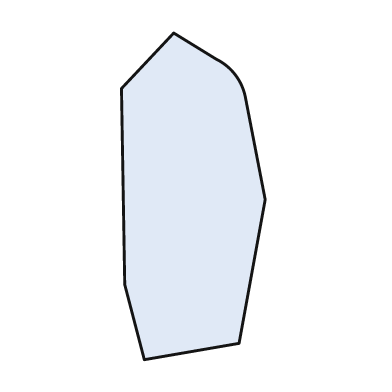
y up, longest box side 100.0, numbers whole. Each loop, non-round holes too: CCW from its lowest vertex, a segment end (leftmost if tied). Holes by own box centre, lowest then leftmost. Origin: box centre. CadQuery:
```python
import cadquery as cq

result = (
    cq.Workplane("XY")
    .moveTo(-15.0, -50.0)
    .lineTo(14.0, -45.0)
    .lineTo(22.0, -1.0)
    .lineTo(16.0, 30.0)
    .threePointArc((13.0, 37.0), (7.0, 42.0))
    .lineTo(-6.0, 50.0)
    .lineTo(-22.0, 33.0)
    .lineTo(-21.0, -27.0)
    .close()
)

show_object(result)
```